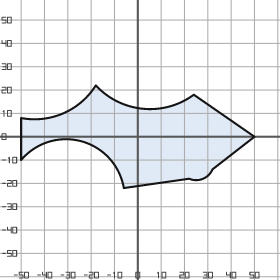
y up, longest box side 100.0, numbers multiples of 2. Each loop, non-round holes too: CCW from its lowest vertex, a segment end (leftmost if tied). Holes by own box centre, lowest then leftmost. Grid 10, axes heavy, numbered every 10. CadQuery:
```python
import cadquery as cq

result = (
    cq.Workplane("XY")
    .moveTo(-6.0, -22.0)
    .lineTo(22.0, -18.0)
    .threePointArc((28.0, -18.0), (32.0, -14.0))
    .lineTo(50.0, 0.0)
    .lineTo(24.0, 18.0)
    .threePointArc((2.0, 12.0), (-18.0, 22.0))
    .threePointArc((-32.0, 10.0), (-50.0, 8.0))
    .lineTo(-50.0, -10.0)
    .threePointArc((-24.0, -2.0), (-6.0, -22.0))
    .close()
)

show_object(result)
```